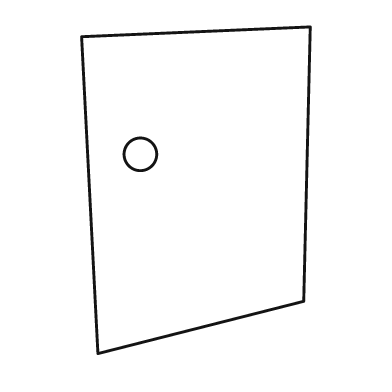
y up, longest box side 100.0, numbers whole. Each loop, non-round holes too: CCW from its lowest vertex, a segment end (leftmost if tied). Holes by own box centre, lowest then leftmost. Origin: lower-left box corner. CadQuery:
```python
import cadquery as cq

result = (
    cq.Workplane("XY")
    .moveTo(5.0, 0.0)
    .lineTo(68.0, 16.0)
    .lineTo(70.0, 100.0)
    .lineTo(0.0, 97.0)
    .close()
    .moveTo(18.0, 61.0)
    .circle(5.0)
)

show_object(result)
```